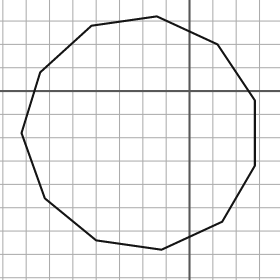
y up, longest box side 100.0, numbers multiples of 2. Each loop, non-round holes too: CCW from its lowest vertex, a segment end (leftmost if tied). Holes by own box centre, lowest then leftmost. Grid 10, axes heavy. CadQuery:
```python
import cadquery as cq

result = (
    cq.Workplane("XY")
    .moveTo(-12.0, -68.0)
    .lineTo(14.0, -56.0)
    .lineTo(28.0, -32.0)
    .lineTo(28.0, -4.0)
    .lineTo(12.0, 20.0)
    .lineTo(-14.0, 32.0)
    .lineTo(-42.0, 28.0)
    .lineTo(-64.0, 8.0)
    .lineTo(-72.0, -18.0)
    .lineTo(-62.0, -46.0)
    .lineTo(-40.0, -64.0)
    .close()
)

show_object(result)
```